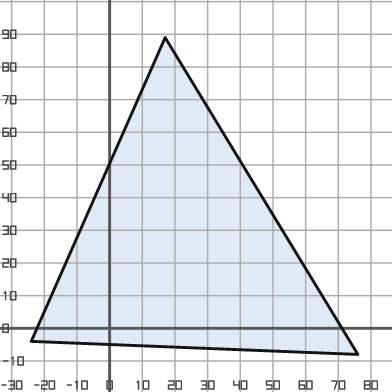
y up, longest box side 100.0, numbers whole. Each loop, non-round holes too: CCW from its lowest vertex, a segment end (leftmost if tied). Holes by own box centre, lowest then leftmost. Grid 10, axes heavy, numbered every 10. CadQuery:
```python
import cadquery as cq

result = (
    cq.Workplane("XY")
    .moveTo(76.0, -8.0)
    .lineTo(17.0, 89.0)
    .lineTo(-24.0, -4.0)
    .close()
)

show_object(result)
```